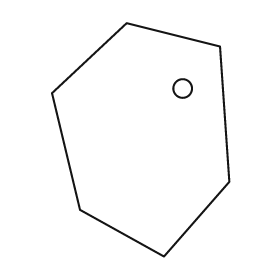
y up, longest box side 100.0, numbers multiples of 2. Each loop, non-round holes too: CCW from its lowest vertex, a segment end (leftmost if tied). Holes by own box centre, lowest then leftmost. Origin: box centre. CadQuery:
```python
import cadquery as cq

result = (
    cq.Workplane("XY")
    .moveTo(10.0, -50.0)
    .lineTo(38.0, -18.0)
    .lineTo(34.0, 40.0)
    .lineTo(-6.0, 50.0)
    .lineTo(-38.0, 20.0)
    .lineTo(-26.0, -30.0)
    .close()
    .moveTo(18.0, 22.0)
    .circle(4.0)
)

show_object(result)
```